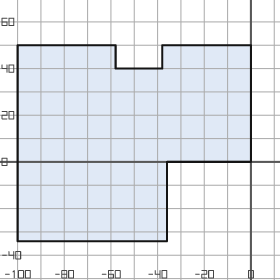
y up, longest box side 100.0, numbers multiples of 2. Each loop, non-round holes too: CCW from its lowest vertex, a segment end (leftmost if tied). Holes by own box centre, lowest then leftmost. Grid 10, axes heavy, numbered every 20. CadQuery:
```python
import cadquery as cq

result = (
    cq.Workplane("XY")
    .moveTo(-100.0, -34.0)
    .lineTo(-36.0, -34.0)
    .lineTo(-36.0, 0.0)
    .lineTo(0.0, 0.0)
    .lineTo(0.0, 50.0)
    .lineTo(-38.0, 50.0)
    .lineTo(-38.0, 40.0)
    .lineTo(-58.0, 40.0)
    .lineTo(-58.0, 50.0)
    .lineTo(-100.0, 50.0)
    .close()
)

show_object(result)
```